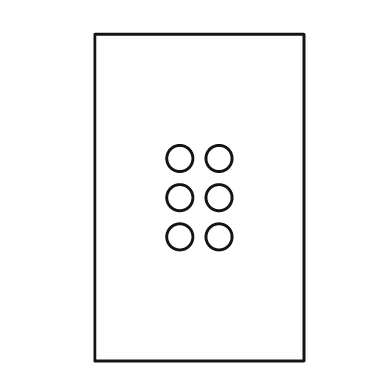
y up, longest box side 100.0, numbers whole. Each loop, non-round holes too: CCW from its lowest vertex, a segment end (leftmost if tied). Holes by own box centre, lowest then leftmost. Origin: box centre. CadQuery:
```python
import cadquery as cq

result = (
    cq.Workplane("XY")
    .moveTo(-32.0, -50.0)
    .lineTo(32.0, -50.0)
    .lineTo(32.0, 50.0)
    .lineTo(-32.0, 50.0)
    .close()
    .moveTo(-6.0, -12.0)
    .circle(4.0)
    .moveTo(6.0, -12.0)
    .circle(4.0)
    .moveTo(-6.0, 0.0)
    .circle(4.0)
    .moveTo(6.0, 0.0)
    .circle(4.0)
    .moveTo(-6.0, 12.0)
    .circle(4.0)
    .moveTo(6.0, 12.0)
    .circle(4.0)
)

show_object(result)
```